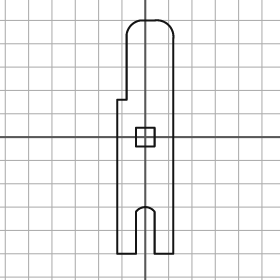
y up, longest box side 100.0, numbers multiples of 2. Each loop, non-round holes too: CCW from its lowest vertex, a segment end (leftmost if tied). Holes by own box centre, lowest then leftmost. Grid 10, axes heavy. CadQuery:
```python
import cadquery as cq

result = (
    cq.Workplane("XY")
    .moveTo(-12.0, -50.0)
    .lineTo(-4.0, -50.0)
    .lineTo(-4.0, -32.0)
    .threePointArc((0.0, -30.0), (4.0, -32.0))
    .lineTo(4.0, -50.0)
    .lineTo(12.0, -50.0)
    .lineTo(12.0, 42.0)
    .threePointArc((10.0, 48.0), (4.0, 50.0))
    .lineTo(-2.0, 50.0)
    .threePointArc((-6.0, 48.0), (-8.0, 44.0))
    .lineTo(-8.0, 16.0)
    .lineTo(-12.0, 16.0)
    .close()
    .moveTo(-4.0, -4.0)
    .lineTo(4.0, -4.0)
    .lineTo(4.0, 4.0)
    .lineTo(-4.0, 4.0)
    .close()
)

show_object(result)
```